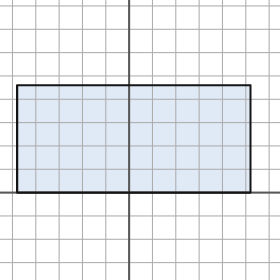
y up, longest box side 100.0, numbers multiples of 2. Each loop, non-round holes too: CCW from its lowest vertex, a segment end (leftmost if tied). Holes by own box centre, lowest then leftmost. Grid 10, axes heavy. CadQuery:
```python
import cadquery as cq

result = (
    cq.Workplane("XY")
    .moveTo(-48.0, 0.0)
    .lineTo(52.0, 0.0)
    .lineTo(52.0, 46.0)
    .lineTo(-48.0, 46.0)
    .close()
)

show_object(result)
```